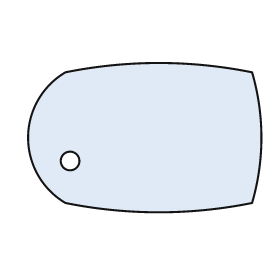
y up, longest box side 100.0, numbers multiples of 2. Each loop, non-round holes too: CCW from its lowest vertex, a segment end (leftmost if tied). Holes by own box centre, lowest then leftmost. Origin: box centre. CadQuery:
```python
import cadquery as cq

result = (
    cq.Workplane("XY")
    .moveTo(-34.0, -28.0)
    .threePointArc((6.0, -32.0), (46.0, -28.0))
    .threePointArc((50.0, 0.0), (46.0, 28.0))
    .threePointArc((6.0, 32.0), (-34.0, 28.0))
    .threePointArc((-50.0, 0.0), (-34.0, -28.0))
    .close()
    .moveTo(-32.0, -10.0)
    .circle(4.0)
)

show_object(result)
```